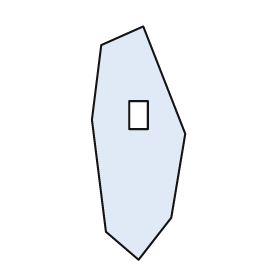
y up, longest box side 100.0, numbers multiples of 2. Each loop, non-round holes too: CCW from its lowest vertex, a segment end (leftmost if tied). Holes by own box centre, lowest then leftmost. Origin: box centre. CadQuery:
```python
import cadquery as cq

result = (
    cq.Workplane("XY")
    .moveTo(0.0, -50.0)
    .lineTo(14.0, -32.0)
    .lineTo(20.0, 4.0)
    .lineTo(2.0, 50.0)
    .lineTo(-16.0, 42.0)
    .lineTo(-20.0, 10.0)
    .lineTo(-14.0, -38.0)
    .close()
    .moveTo(-4.0, 6.0)
    .lineTo(4.0, 6.0)
    .lineTo(4.0, 18.0)
    .lineTo(-4.0, 18.0)
    .close()
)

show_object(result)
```